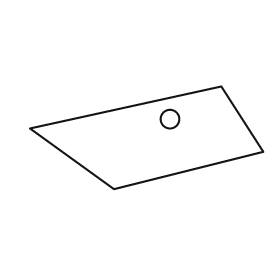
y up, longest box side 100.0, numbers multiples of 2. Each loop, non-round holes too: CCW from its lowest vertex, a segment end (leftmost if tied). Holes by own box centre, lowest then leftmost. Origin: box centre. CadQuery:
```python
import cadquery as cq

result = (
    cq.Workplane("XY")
    .moveTo(-14.0, -22.0)
    .lineTo(50.0, -6.0)
    .lineTo(32.0, 22.0)
    .lineTo(-50.0, 4.0)
    .close()
    .moveTo(10.0, 8.0)
    .circle(4.0)
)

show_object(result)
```